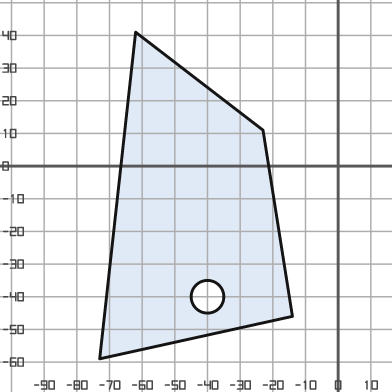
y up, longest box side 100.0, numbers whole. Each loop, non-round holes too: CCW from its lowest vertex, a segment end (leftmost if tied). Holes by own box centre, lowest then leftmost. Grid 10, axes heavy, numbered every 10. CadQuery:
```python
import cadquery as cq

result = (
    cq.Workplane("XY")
    .moveTo(-73.0, -59.0)
    .lineTo(-14.0, -46.0)
    .lineTo(-23.0, 11.0)
    .lineTo(-62.0, 41.0)
    .close()
    .moveTo(-40.0, -40.0)
    .circle(5.0)
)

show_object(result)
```